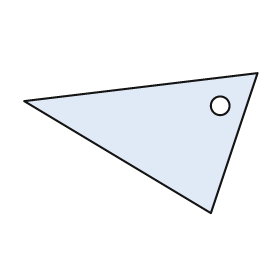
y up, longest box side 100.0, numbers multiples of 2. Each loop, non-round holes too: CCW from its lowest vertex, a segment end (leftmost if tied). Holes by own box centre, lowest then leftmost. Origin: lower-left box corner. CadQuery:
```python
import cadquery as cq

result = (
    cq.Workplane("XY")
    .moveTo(80.0, 0.0)
    .lineTo(100.0, 60.0)
    .lineTo(0.0, 48.0)
    .close()
    .moveTo(84.0, 46.0)
    .circle(4.0)
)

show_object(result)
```